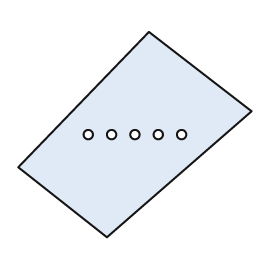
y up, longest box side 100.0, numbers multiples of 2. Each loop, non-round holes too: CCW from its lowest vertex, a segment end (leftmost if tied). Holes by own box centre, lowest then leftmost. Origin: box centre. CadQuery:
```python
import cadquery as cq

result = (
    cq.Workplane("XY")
    .moveTo(-12.0, -44.0)
    .lineTo(50.0, 10.0)
    .lineTo(6.0, 44.0)
    .lineTo(-50.0, -14.0)
    .close()
    .moveTo(-20.0, 0.0)
    .circle(2.0)
    .moveTo(-10.0, 0.0)
    .circle(2.0)
    .moveTo(0.0, 0.0)
    .circle(2.0)
    .moveTo(10.0, 0.0)
    .circle(2.0)
    .moveTo(20.0, 0.0)
    .circle(2.0)
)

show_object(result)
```